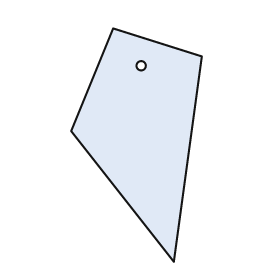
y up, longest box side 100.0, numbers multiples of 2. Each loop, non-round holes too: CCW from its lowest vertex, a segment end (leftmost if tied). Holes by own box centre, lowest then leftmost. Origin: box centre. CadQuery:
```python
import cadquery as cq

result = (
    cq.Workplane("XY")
    .moveTo(16.0, -50.0)
    .lineTo(28.0, 38.0)
    .lineTo(-10.0, 50.0)
    .lineTo(-28.0, 6.0)
    .close()
    .moveTo(2.0, 34.0)
    .circle(2.0)
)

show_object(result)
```